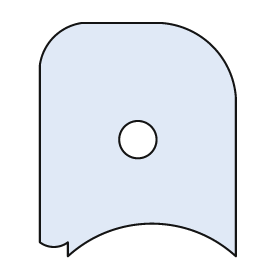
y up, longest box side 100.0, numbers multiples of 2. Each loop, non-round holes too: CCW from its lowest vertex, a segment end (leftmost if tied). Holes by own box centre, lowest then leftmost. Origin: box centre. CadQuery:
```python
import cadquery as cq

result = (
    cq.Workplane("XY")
    .moveTo(-30.0, -50.0)
    .threePointArc((6.0, -36.0), (42.0, -50.0))
    .lineTo(42.0, 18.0)
    .threePointArc((32.0, 40.0), (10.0, 50.0))
    .lineTo(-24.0, 50.0)
    .threePointArc((-36.0, 44.0), (-42.0, 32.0))
    .lineTo(-42.0, -44.0)
    .threePointArc((-36.0, -46.0), (-30.0, -44.0))
    .close()
    .moveTo(0.0, 0.0)
    .circle(8.0)
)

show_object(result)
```